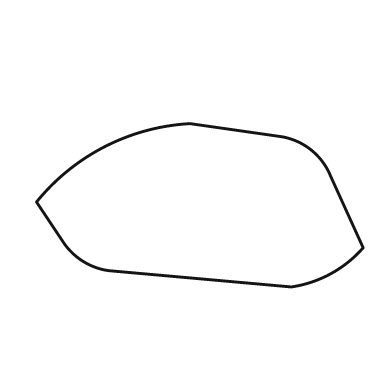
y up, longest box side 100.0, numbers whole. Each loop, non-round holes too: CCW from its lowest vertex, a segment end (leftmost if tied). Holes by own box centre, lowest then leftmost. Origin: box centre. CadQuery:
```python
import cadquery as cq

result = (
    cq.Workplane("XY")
    .moveTo(28.0, -25.0)
    .threePointArc((40.0, -21.0), (50.0, -13.0))
    .lineTo(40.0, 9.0)
    .threePointArc((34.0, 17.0), (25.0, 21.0))
    .lineTo(-3.0, 25.0)
    .threePointArc((-29.0, 18.0), (-50.0, 1.0))
    .lineTo(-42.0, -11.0)
    .threePointArc((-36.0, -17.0), (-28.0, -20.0))
    .close()
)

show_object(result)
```